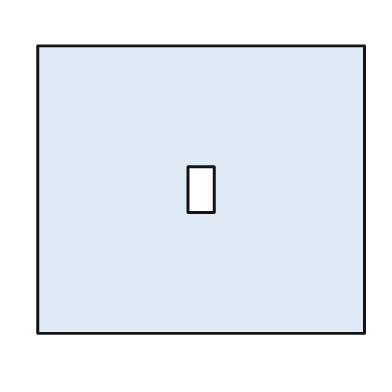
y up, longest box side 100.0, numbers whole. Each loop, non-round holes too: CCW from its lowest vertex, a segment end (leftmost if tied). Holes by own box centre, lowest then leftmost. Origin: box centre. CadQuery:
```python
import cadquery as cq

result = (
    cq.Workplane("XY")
    .moveTo(-50.0, -44.0)
    .lineTo(50.0, -44.0)
    .lineTo(50.0, 44.0)
    .lineTo(-50.0, 44.0)
    .close()
    .moveTo(-4.0, -7.0)
    .lineTo(4.0, -7.0)
    .lineTo(4.0, 7.0)
    .lineTo(-4.0, 7.0)
    .close()
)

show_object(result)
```